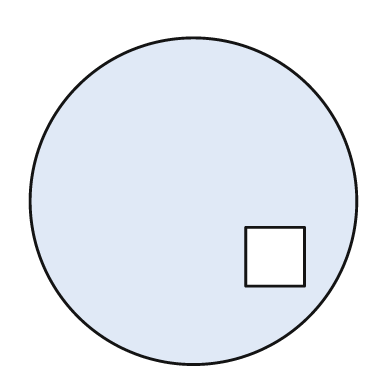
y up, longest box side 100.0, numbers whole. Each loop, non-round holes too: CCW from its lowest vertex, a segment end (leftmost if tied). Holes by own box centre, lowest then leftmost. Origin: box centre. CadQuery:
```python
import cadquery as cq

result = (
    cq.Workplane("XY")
    .moveTo(0.0, 0.0)
    .circle(50.0)
    .moveTo(16.0, -26.0)
    .lineTo(34.0, -26.0)
    .lineTo(34.0, -8.0)
    .lineTo(16.0, -8.0)
    .close()
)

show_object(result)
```